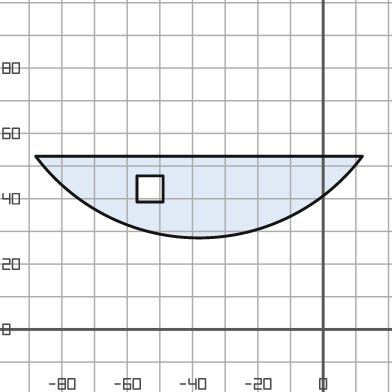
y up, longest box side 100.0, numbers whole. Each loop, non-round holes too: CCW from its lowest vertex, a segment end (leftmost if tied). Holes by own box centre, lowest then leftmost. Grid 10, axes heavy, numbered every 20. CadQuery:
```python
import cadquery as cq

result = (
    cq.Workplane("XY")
    .moveTo(-88.0, 53.0)
    .threePointArc((-38.0, 28.0), (12.0, 53.0))
    .close()
    .moveTo(-57.0, 39.0)
    .lineTo(-49.0, 39.0)
    .lineTo(-49.0, 47.0)
    .lineTo(-57.0, 47.0)
    .close()
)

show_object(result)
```